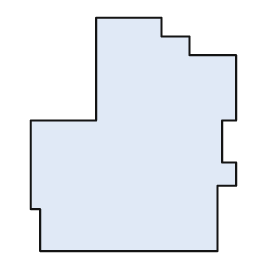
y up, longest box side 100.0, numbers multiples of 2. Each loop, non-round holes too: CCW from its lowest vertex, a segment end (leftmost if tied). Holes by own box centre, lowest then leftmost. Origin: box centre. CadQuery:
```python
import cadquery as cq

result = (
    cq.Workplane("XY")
    .moveTo(-40.0, -50.0)
    .lineTo(36.0, -50.0)
    .lineTo(36.0, -22.0)
    .lineTo(44.0, -22.0)
    .lineTo(44.0, -12.0)
    .lineTo(38.0, -12.0)
    .lineTo(38.0, 6.0)
    .lineTo(44.0, 6.0)
    .lineTo(44.0, 34.0)
    .lineTo(24.0, 34.0)
    .lineTo(24.0, 42.0)
    .lineTo(12.0, 42.0)
    .lineTo(12.0, 50.0)
    .lineTo(-16.0, 50.0)
    .lineTo(-16.0, 6.0)
    .lineTo(-44.0, 6.0)
    .lineTo(-44.0, -32.0)
    .lineTo(-40.0, -32.0)
    .close()
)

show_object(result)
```